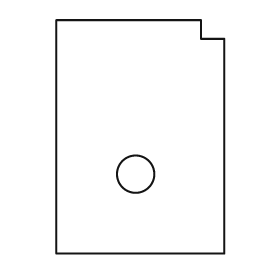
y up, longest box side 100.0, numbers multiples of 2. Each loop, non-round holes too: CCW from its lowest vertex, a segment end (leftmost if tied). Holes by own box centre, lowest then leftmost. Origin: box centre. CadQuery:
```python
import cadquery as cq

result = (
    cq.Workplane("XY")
    .moveTo(-36.0, -50.0)
    .lineTo(36.0, -50.0)
    .lineTo(36.0, 42.0)
    .lineTo(26.0, 42.0)
    .lineTo(26.0, 50.0)
    .lineTo(-36.0, 50.0)
    .close()
    .moveTo(-2.0, -16.0)
    .circle(8.0)
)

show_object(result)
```